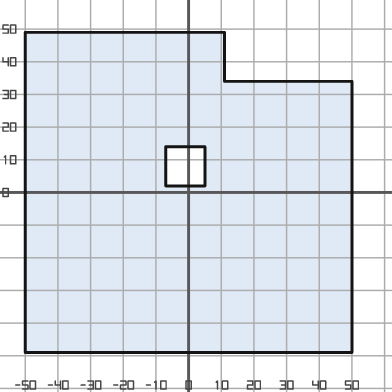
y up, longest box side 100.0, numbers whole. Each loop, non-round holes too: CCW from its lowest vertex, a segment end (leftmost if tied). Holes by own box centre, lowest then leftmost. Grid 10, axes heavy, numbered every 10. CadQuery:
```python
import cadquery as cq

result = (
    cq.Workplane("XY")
    .moveTo(-50.0, -49.0)
    .lineTo(50.0, -49.0)
    .lineTo(50.0, 34.0)
    .lineTo(11.0, 34.0)
    .lineTo(11.0, 49.0)
    .lineTo(-50.0, 49.0)
    .close()
    .moveTo(-7.0, 2.0)
    .lineTo(5.0, 2.0)
    .lineTo(5.0, 14.0)
    .lineTo(-7.0, 14.0)
    .close()
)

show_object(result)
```